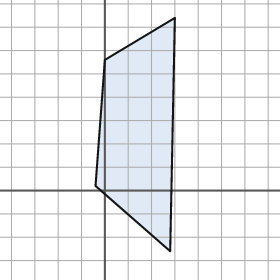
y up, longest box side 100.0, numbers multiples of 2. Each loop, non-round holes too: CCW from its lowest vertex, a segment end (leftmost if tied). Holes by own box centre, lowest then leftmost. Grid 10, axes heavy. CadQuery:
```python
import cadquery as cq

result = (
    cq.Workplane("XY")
    .moveTo(28.0, -26.0)
    .lineTo(30.0, 74.0)
    .lineTo(0.0, 56.0)
    .lineTo(-4.0, 2.0)
    .close()
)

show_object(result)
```